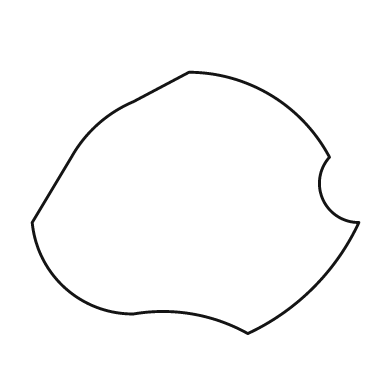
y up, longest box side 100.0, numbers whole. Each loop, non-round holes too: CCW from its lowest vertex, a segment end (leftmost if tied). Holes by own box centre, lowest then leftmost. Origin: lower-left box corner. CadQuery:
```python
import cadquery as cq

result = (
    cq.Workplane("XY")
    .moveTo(66.0, 0.0)
    .threePointArc((86.0, 14.0), (100.0, 34.0))
    .threePointArc((89.0, 41.0), (91.0, 54.0))
    .threePointArc((73.0, 73.0), (48.0, 80.0))
    .lineTo(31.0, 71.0)
    .threePointArc((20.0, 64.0), (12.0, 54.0))
    .lineTo(0.0, 34.0)
    .threePointArc((10.0, 14.0), (31.0, 6.0))
    .threePointArc((49.0, 6.0), (66.0, 0.0))
    .close()
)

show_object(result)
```